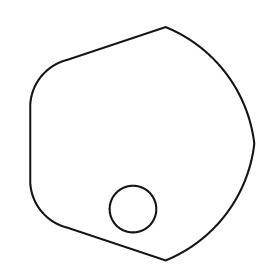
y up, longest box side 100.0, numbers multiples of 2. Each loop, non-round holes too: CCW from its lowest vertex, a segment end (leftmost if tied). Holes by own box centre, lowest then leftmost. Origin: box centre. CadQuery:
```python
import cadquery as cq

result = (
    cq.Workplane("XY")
    .moveTo(10.0, -50.0)
    .threePointArc((36.0, -30.0), (48.0, 0.0))
    .threePointArc((36.0, 30.0), (10.0, 50.0))
    .lineTo(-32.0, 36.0)
    .threePointArc((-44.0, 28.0), (-48.0, 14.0))
    .lineTo(-48.0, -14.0)
    .threePointArc((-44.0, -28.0), (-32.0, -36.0))
    .close()
    .moveTo(-4.0, -28.0)
    .circle(10.0)
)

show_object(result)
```